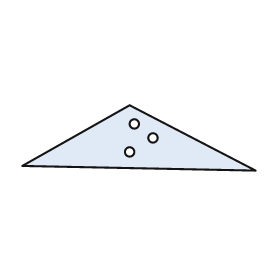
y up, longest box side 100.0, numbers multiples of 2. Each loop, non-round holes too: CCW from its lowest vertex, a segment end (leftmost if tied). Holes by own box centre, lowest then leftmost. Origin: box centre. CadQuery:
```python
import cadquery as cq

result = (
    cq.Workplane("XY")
    .moveTo(50.0, -14.0)
    .lineTo(-4.0, 14.0)
    .lineTo(-50.0, -12.0)
    .close()
    .moveTo(-4.0, -6.0)
    .circle(2.0)
    .moveTo(6.0, 0.0)
    .circle(2.0)
    .moveTo(-2.0, 6.0)
    .circle(2.0)
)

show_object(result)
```